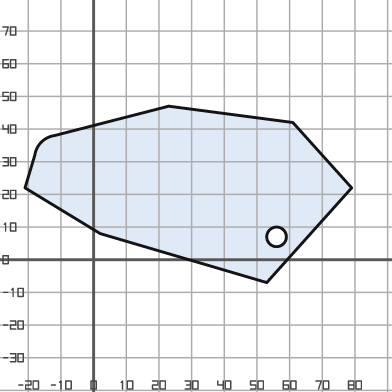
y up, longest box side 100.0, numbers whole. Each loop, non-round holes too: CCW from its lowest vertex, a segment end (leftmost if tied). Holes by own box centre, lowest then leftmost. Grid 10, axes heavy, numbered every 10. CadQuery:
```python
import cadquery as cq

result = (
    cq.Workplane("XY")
    .moveTo(53.0, -7.0)
    .lineTo(79.0, 22.0)
    .lineTo(61.0, 42.0)
    .lineTo(23.0, 47.0)
    .lineTo(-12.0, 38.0)
    .threePointArc((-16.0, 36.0), (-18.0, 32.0))
    .lineTo(-21.0, 22.0)
    .lineTo(2.0, 8.0)
    .close()
    .moveTo(56.0, 7.0)
    .circle(3.0)
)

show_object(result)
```